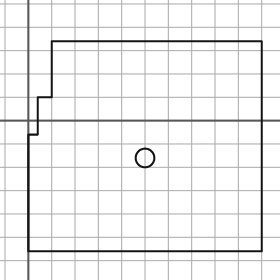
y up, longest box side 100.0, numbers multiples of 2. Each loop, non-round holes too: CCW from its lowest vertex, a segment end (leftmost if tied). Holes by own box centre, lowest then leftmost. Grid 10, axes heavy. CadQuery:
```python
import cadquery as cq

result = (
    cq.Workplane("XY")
    .moveTo(0.0, -56.0)
    .lineTo(100.0, -56.0)
    .lineTo(100.0, 34.0)
    .lineTo(10.0, 34.0)
    .lineTo(10.0, 10.0)
    .lineTo(4.0, 10.0)
    .lineTo(4.0, -6.0)
    .lineTo(0.0, -6.0)
    .close()
    .moveTo(50.0, -16.0)
    .circle(4.0)
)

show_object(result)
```